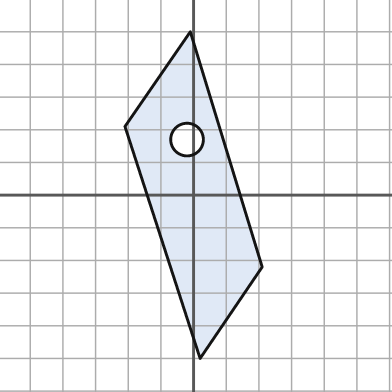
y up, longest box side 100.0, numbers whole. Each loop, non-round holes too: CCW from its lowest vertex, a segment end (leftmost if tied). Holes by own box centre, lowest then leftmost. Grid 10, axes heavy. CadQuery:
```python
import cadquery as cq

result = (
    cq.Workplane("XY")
    .moveTo(2.0, -50.0)
    .lineTo(21.0, -22.0)
    .lineTo(-1.0, 50.0)
    .lineTo(-21.0, 21.0)
    .close()
    .moveTo(-2.0, 17.0)
    .circle(5.0)
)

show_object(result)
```